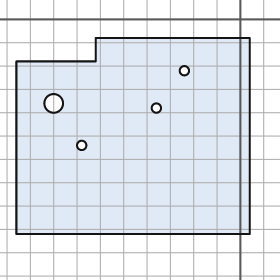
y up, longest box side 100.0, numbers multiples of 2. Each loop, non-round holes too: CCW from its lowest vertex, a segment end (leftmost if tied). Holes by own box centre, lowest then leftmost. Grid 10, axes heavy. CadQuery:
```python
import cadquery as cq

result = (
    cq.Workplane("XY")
    .moveTo(-96.0, -92.0)
    .lineTo(4.0, -92.0)
    .lineTo(4.0, -8.0)
    .lineTo(-62.0, -8.0)
    .lineTo(-62.0, -18.0)
    .lineTo(-96.0, -18.0)
    .close()
    .moveTo(-68.0, -54.0)
    .circle(2.0)
    .moveTo(-36.0, -38.0)
    .circle(2.0)
    .moveTo(-80.0, -36.0)
    .circle(4.0)
    .moveTo(-24.0, -22.0)
    .circle(2.0)
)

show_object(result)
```